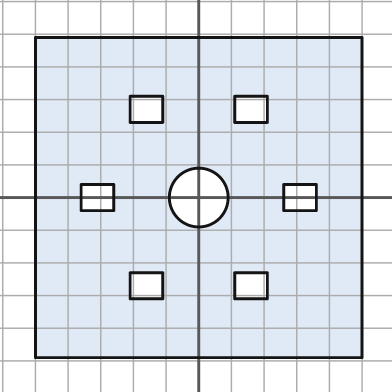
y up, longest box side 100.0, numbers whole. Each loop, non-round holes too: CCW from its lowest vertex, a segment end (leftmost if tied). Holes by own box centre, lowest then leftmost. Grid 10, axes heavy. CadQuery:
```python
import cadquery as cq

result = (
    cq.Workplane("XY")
    .moveTo(-50.0, -49.0)
    .lineTo(50.0, -49.0)
    .lineTo(50.0, 49.0)
    .lineTo(-50.0, 49.0)
    .close()
    .moveTo(-21.0, -31.0)
    .lineTo(-11.0, -31.0)
    .lineTo(-11.0, -23.0)
    .lineTo(-21.0, -23.0)
    .close()
    .moveTo(11.0, -31.0)
    .lineTo(21.0, -31.0)
    .lineTo(21.0, -23.0)
    .lineTo(11.0, -23.0)
    .close()
    .moveTo(-36.0, -4.0)
    .lineTo(-26.0, -4.0)
    .lineTo(-26.0, 4.0)
    .lineTo(-36.0, 4.0)
    .close()
    .moveTo(0.0, 0.0)
    .circle(9.0)
    .moveTo(26.0, -4.0)
    .lineTo(36.0, -4.0)
    .lineTo(36.0, 4.0)
    .lineTo(26.0, 4.0)
    .close()
    .moveTo(-21.0, 23.0)
    .lineTo(-11.0, 23.0)
    .lineTo(-11.0, 31.0)
    .lineTo(-21.0, 31.0)
    .close()
    .moveTo(11.0, 23.0)
    .lineTo(21.0, 23.0)
    .lineTo(21.0, 31.0)
    .lineTo(11.0, 31.0)
    .close()
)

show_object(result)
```